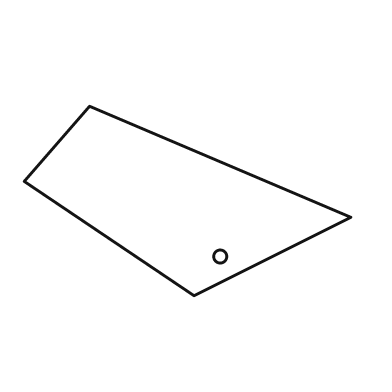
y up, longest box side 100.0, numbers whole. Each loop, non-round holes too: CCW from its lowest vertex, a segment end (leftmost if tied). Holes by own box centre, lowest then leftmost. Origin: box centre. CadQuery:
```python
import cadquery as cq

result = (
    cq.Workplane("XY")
    .moveTo(2.0, -29.0)
    .lineTo(50.0, -5.0)
    .lineTo(-30.0, 29.0)
    .lineTo(-50.0, 6.0)
    .close()
    .moveTo(10.0, -17.0)
    .circle(2.0)
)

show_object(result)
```